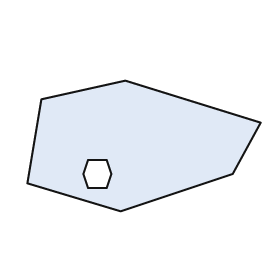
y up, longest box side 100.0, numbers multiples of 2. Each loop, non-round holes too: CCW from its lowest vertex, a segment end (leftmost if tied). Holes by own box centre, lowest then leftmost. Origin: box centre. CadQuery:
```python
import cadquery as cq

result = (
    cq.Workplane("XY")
    .moveTo(-10.0, -28.0)
    .lineTo(38.0, -12.0)
    .lineTo(50.0, 10.0)
    .lineTo(-8.0, 28.0)
    .lineTo(-44.0, 20.0)
    .lineTo(-50.0, -16.0)
    .close()
    .moveTo(-24.0, -18.0)
    .lineTo(-16.0, -18.0)
    .lineTo(-14.0, -12.0)
    .lineTo(-16.0, -6.0)
    .lineTo(-24.0, -6.0)
    .lineTo(-26.0, -12.0)
    .close()
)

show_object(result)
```